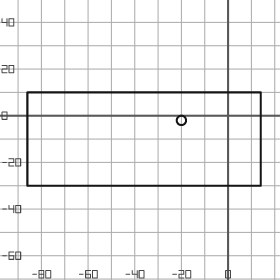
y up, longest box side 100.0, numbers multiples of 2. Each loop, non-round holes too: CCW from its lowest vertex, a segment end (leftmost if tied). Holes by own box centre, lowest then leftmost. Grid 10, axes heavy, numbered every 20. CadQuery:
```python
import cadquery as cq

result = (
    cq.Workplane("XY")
    .moveTo(-86.0, -30.0)
    .lineTo(14.0, -30.0)
    .lineTo(14.0, 10.0)
    .lineTo(-86.0, 10.0)
    .close()
    .moveTo(-20.0, -2.0)
    .circle(2.0)
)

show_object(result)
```